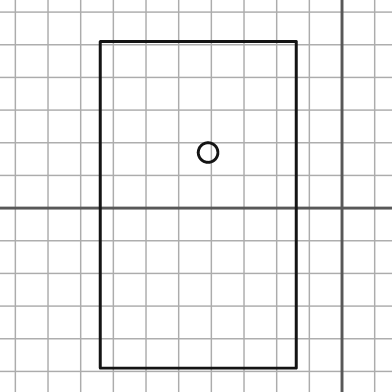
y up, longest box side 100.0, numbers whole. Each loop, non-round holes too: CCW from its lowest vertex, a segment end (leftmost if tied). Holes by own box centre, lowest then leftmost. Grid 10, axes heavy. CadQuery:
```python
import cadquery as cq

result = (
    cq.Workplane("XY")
    .moveTo(-74.0, -49.0)
    .lineTo(-14.0, -49.0)
    .lineTo(-14.0, 51.0)
    .lineTo(-74.0, 51.0)
    .close()
    .moveTo(-41.0, 17.0)
    .circle(3.0)
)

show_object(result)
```